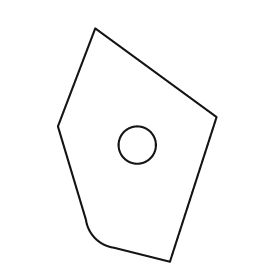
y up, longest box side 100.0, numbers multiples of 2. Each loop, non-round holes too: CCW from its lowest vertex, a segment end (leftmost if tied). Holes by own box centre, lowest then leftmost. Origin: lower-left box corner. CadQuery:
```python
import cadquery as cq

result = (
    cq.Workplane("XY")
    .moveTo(48.0, 0.0)
    .lineTo(68.0, 62.0)
    .lineTo(16.0, 100.0)
    .lineTo(0.0, 58.0)
    .lineTo(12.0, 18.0)
    .threePointArc((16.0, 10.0), (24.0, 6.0))
    .close()
    .moveTo(34.0, 50.0)
    .circle(8.0)
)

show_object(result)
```